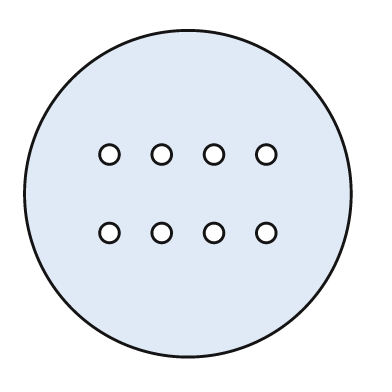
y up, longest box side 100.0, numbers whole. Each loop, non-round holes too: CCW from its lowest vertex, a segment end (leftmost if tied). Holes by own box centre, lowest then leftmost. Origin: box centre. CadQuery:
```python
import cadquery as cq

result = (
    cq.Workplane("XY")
    .moveTo(0.0, 0.0)
    .circle(50.0)
    .moveTo(-24.0, -12.0)
    .circle(3.0)
    .moveTo(-8.0, -12.0)
    .circle(3.0)
    .moveTo(8.0, -12.0)
    .circle(3.0)
    .moveTo(24.0, -12.0)
    .circle(3.0)
    .moveTo(-24.0, 12.0)
    .circle(3.0)
    .moveTo(-8.0, 12.0)
    .circle(3.0)
    .moveTo(8.0, 12.0)
    .circle(3.0)
    .moveTo(24.0, 12.0)
    .circle(3.0)
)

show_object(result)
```